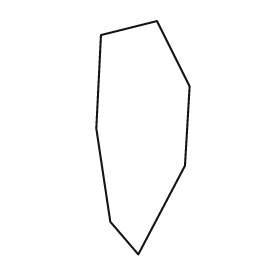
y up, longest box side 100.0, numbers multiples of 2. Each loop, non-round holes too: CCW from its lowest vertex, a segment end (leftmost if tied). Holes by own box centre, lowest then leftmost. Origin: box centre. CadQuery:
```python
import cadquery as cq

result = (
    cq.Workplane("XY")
    .moveTo(-2.0, -50.0)
    .lineTo(18.0, -12.0)
    .lineTo(20.0, 22.0)
    .lineTo(6.0, 50.0)
    .lineTo(-18.0, 44.0)
    .lineTo(-20.0, 4.0)
    .lineTo(-14.0, -36.0)
    .close()
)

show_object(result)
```